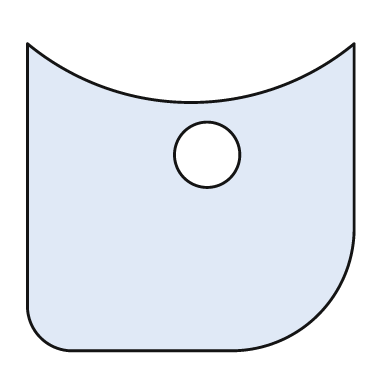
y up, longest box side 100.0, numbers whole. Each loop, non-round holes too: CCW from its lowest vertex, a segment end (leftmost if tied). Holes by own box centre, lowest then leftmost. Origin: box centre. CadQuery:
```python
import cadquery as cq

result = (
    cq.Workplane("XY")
    .moveTo(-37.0, -47.0)
    .lineTo(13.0, -47.0)
    .threePointArc((39.0, -36.0), (50.0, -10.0))
    .lineTo(50.0, 47.0)
    .threePointArc((0.0, 29.0), (-50.0, 47.0))
    .lineTo(-50.0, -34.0)
    .threePointArc((-46.0, -43.0), (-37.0, -47.0))
    .close()
    .moveTo(5.0, 13.0)
    .circle(10.0)
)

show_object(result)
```